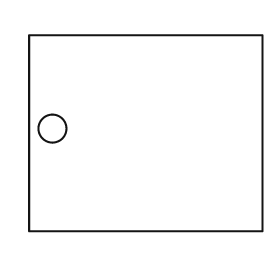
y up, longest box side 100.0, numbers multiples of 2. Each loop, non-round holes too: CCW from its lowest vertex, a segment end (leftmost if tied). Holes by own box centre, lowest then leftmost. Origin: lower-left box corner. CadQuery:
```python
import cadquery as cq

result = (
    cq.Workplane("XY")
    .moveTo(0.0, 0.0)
    .lineTo(100.0, 0.0)
    .lineTo(100.0, 84.0)
    .lineTo(0.0, 84.0)
    .close()
    .moveTo(10.0, 44.0)
    .circle(6.0)
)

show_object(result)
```